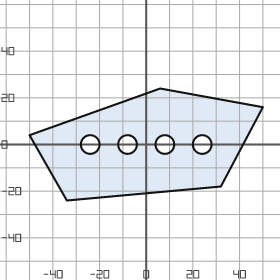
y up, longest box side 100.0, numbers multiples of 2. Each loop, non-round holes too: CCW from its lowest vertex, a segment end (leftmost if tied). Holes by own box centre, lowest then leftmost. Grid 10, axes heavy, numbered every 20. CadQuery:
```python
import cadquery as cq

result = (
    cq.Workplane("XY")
    .moveTo(-34.0, -24.0)
    .lineTo(32.0, -18.0)
    .lineTo(50.0, 16.0)
    .lineTo(6.0, 24.0)
    .lineTo(-50.0, 4.0)
    .close()
    .moveTo(-24.0, 0.0)
    .circle(4.0)
    .moveTo(-8.0, 0.0)
    .circle(4.0)
    .moveTo(8.0, 0.0)
    .circle(4.0)
    .moveTo(24.0, 0.0)
    .circle(4.0)
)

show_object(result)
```